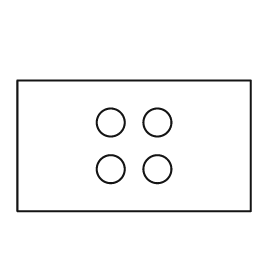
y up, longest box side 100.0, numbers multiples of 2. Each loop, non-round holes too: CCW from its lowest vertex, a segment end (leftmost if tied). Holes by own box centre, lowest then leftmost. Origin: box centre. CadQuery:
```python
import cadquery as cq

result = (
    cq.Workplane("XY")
    .moveTo(-50.0, -28.0)
    .lineTo(50.0, -28.0)
    .lineTo(50.0, 28.0)
    .lineTo(-50.0, 28.0)
    .close()
    .moveTo(-10.0, -10.0)
    .circle(6.0)
    .moveTo(10.0, -10.0)
    .circle(6.0)
    .moveTo(-10.0, 10.0)
    .circle(6.0)
    .moveTo(10.0, 10.0)
    .circle(6.0)
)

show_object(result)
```